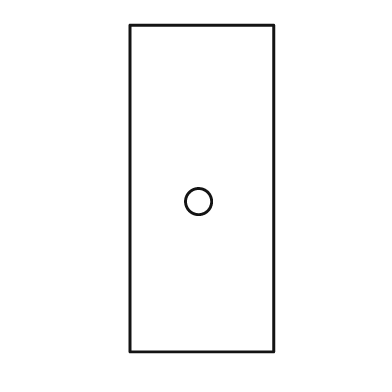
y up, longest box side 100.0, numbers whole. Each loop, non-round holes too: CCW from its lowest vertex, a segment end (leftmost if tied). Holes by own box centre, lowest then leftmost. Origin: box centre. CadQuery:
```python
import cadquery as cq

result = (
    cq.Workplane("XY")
    .moveTo(-22.0, -50.0)
    .lineTo(22.0, -50.0)
    .lineTo(22.0, 50.0)
    .lineTo(-22.0, 50.0)
    .close()
    .moveTo(-1.0, -4.0)
    .circle(4.0)
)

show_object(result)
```